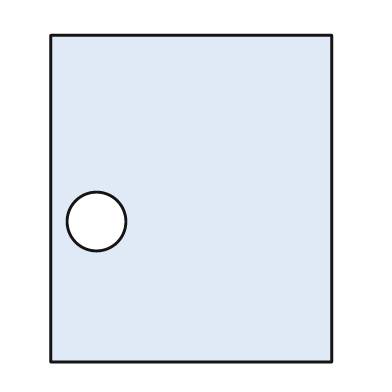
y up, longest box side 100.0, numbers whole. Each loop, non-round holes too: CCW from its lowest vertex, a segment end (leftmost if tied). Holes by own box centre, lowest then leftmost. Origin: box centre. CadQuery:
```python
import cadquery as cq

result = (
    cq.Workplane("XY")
    .moveTo(-43.0, -50.0)
    .lineTo(43.0, -50.0)
    .lineTo(43.0, 50.0)
    .lineTo(-43.0, 50.0)
    .close()
    .moveTo(-29.0, -7.0)
    .circle(9.0)
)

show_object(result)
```